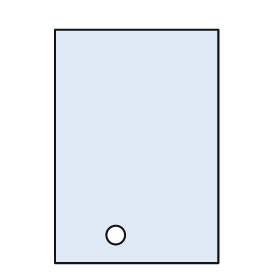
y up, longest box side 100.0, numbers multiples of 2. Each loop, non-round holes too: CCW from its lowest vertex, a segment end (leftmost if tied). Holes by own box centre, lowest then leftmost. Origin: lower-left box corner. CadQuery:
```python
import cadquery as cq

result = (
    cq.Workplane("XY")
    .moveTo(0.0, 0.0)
    .lineTo(70.0, 0.0)
    .lineTo(70.0, 100.0)
    .lineTo(0.0, 100.0)
    .close()
    .moveTo(26.0, 12.0)
    .circle(4.0)
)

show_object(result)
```